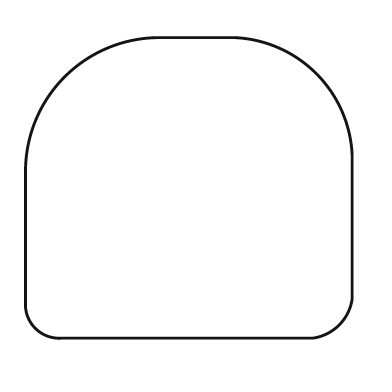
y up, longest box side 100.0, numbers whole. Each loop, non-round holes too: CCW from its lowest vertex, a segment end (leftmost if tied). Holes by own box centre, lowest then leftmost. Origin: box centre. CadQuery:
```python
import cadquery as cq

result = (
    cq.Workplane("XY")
    .moveTo(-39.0, -46.0)
    .lineTo(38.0, -46.0)
    .threePointArc((46.0, -42.0), (50.0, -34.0))
    .lineTo(50.0, 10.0)
    .threePointArc((39.0, 35.0), (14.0, 46.0))
    .lineTo(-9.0, 46.0)
    .threePointArc((-38.0, 34.0), (-50.0, 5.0))
    .lineTo(-50.0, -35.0)
    .threePointArc((-47.0, -43.0), (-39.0, -46.0))
    .close()
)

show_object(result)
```